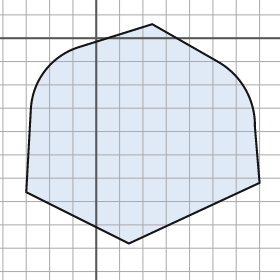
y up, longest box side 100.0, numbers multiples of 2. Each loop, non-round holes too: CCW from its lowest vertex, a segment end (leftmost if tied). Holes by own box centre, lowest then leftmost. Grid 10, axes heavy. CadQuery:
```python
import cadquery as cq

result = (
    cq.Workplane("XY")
    .moveTo(14.0, -88.0)
    .lineTo(70.0, -62.0)
    .lineTo(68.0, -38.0)
    .threePointArc((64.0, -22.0), (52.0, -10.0))
    .lineTo(24.0, 6.0)
    .lineTo(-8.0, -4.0)
    .threePointArc((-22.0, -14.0), (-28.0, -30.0))
    .lineTo(-30.0, -66.0)
    .close()
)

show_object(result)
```